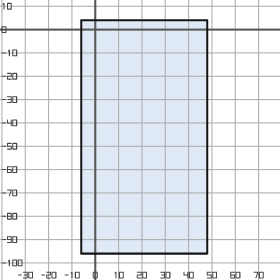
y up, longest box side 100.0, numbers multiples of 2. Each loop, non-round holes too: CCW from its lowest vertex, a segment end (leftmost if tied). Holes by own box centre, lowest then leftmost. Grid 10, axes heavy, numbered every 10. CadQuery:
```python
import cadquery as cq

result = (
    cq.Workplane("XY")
    .moveTo(-6.0, -96.0)
    .lineTo(48.0, -96.0)
    .lineTo(48.0, 4.0)
    .lineTo(-6.0, 4.0)
    .close()
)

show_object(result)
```